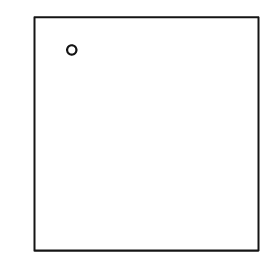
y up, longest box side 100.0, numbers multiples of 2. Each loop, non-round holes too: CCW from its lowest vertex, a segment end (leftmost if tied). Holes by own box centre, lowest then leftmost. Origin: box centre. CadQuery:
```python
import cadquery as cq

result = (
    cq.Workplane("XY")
    .moveTo(-48.0, -50.0)
    .lineTo(48.0, -50.0)
    .lineTo(48.0, 50.0)
    .lineTo(-48.0, 50.0)
    .close()
    .moveTo(-32.0, 36.0)
    .circle(2.0)
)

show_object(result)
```